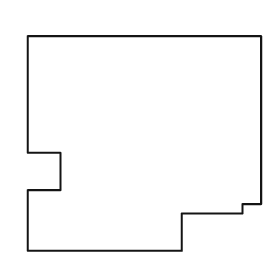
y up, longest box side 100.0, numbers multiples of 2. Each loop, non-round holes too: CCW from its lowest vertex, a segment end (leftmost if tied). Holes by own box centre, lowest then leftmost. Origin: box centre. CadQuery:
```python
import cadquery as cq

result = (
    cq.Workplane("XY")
    .moveTo(-50.0, -46.0)
    .lineTo(16.0, -46.0)
    .lineTo(16.0, -30.0)
    .lineTo(42.0, -30.0)
    .lineTo(42.0, -26.0)
    .lineTo(50.0, -26.0)
    .lineTo(50.0, 46.0)
    .lineTo(-50.0, 46.0)
    .lineTo(-50.0, -4.0)
    .lineTo(-36.0, -4.0)
    .lineTo(-36.0, -20.0)
    .lineTo(-50.0, -20.0)
    .close()
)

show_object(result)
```